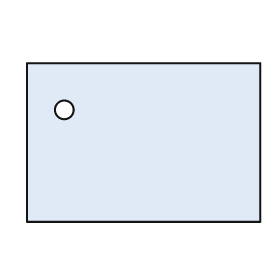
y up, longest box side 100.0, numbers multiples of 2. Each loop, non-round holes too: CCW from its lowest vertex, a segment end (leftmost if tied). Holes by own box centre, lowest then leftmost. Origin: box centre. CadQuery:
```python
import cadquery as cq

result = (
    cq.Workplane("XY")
    .moveTo(-50.0, -34.0)
    .lineTo(50.0, -34.0)
    .lineTo(50.0, 34.0)
    .lineTo(-50.0, 34.0)
    .close()
    .moveTo(-34.0, 14.0)
    .circle(4.0)
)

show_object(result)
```